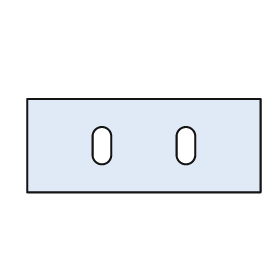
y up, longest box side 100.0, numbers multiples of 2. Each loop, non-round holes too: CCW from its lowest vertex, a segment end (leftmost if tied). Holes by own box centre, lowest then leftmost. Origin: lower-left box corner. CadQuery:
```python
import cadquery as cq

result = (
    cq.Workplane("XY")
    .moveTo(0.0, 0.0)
    .lineTo(100.0, 0.0)
    .lineTo(100.0, 40.0)
    .lineTo(0.0, 40.0)
    .close()
    .moveTo(28.0, 16.0)
    .threePointArc((32.0, 12.0), (36.0, 16.0))
    .lineTo(36.0, 24.0)
    .threePointArc((32.0, 28.0), (28.0, 24.0))
    .close()
    .moveTo(64.0, 16.0)
    .threePointArc((68.0, 12.0), (72.0, 16.0))
    .lineTo(72.0, 24.0)
    .threePointArc((68.0, 28.0), (64.0, 24.0))
    .close()
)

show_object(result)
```